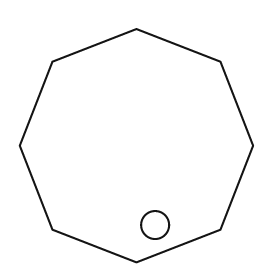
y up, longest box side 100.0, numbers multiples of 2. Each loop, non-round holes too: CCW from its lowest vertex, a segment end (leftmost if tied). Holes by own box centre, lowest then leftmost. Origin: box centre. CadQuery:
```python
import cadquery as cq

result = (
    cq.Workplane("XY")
    .moveTo(0.0, -50.0)
    .lineTo(36.0, -36.0)
    .lineTo(50.0, 0.0)
    .lineTo(36.0, 36.0)
    .lineTo(0.0, 50.0)
    .lineTo(-36.0, 36.0)
    .lineTo(-50.0, 0.0)
    .lineTo(-36.0, -36.0)
    .close()
    .moveTo(8.0, -34.0)
    .circle(6.0)
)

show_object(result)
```